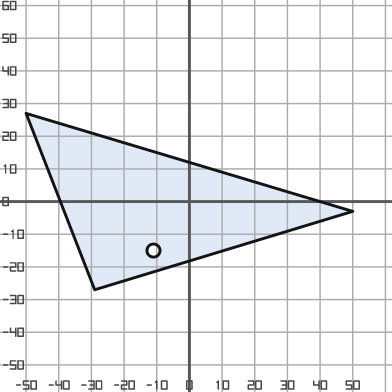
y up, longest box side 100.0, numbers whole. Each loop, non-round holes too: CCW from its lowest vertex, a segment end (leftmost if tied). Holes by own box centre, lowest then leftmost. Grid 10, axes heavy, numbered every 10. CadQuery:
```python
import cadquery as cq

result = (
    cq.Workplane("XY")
    .moveTo(-29.0, -27.0)
    .lineTo(50.0, -3.0)
    .lineTo(-50.0, 27.0)
    .close()
    .moveTo(-11.0, -15.0)
    .circle(2.0)
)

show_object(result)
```